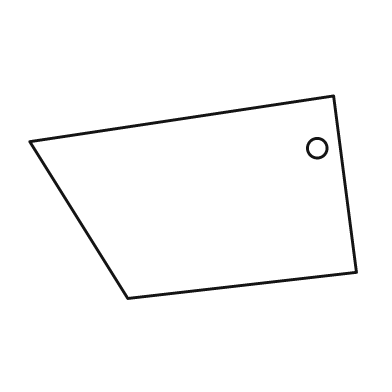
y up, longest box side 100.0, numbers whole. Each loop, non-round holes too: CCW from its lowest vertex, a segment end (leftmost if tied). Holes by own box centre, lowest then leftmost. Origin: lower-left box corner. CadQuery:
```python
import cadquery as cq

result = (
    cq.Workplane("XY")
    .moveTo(30.0, 0.0)
    .lineTo(100.0, 8.0)
    .lineTo(93.0, 62.0)
    .lineTo(0.0, 48.0)
    .close()
    .moveTo(88.0, 46.0)
    .circle(3.0)
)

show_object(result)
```